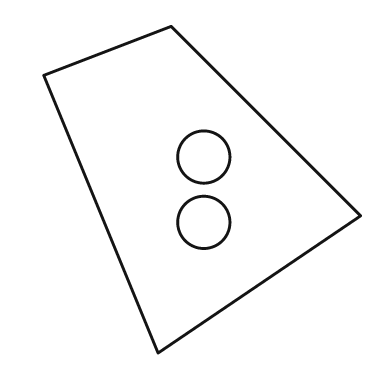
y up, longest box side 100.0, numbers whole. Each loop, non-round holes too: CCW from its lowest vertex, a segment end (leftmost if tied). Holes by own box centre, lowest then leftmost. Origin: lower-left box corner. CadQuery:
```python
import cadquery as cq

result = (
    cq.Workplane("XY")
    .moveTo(35.0, 0.0)
    .lineTo(97.0, 42.0)
    .lineTo(39.0, 100.0)
    .lineTo(0.0, 85.0)
    .close()
    .moveTo(49.0, 40.0)
    .circle(8.0)
    .moveTo(49.0, 60.0)
    .circle(8.0)
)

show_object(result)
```